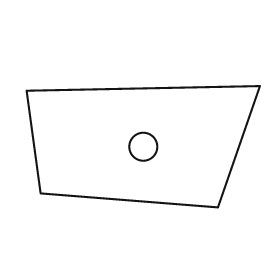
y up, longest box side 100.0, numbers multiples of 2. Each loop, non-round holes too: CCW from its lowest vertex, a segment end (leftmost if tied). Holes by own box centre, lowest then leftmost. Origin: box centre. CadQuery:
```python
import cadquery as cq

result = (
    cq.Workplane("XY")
    .moveTo(32.0, -26.0)
    .lineTo(50.0, 26.0)
    .lineTo(-50.0, 24.0)
    .lineTo(-44.0, -20.0)
    .close()
    .moveTo(0.0, 0.0)
    .circle(6.0)
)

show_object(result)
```